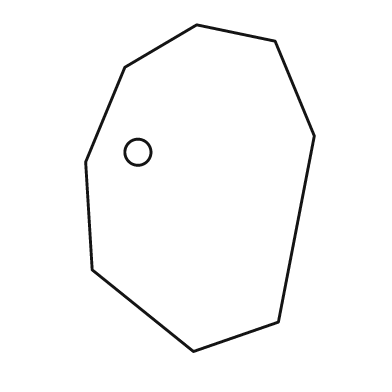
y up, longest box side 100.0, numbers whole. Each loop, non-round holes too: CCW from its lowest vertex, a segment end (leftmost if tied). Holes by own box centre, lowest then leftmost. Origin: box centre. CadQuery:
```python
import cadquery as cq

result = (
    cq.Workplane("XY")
    .moveTo(-2.0, -50.0)
    .lineTo(24.0, -41.0)
    .lineTo(35.0, 16.0)
    .lineTo(23.0, 45.0)
    .lineTo(-1.0, 50.0)
    .lineTo(-23.0, 37.0)
    .lineTo(-35.0, 8.0)
    .lineTo(-33.0, -25.0)
    .close()
    .moveTo(-19.0, 11.0)
    .circle(4.0)
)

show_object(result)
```